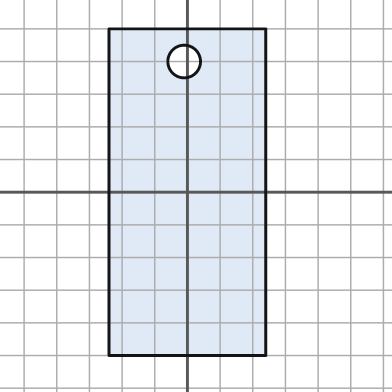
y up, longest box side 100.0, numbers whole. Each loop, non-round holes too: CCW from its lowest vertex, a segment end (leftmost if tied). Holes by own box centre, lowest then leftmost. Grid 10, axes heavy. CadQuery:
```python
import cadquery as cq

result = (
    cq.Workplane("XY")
    .moveTo(-24.0, -50.0)
    .lineTo(24.0, -50.0)
    .lineTo(24.0, 50.0)
    .lineTo(-24.0, 50.0)
    .close()
    .moveTo(-1.0, 40.0)
    .circle(5.0)
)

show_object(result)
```